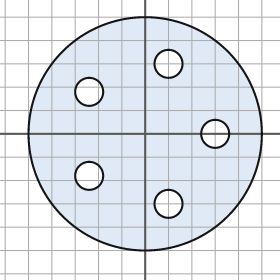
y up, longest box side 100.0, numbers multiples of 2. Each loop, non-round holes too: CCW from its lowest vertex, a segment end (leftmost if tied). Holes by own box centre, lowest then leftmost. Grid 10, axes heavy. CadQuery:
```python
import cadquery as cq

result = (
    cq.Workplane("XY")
    .moveTo(0.0, 0.0)
    .circle(50.0)
    .moveTo(10.0, -30.0)
    .circle(6.0)
    .moveTo(-24.0, -18.0)
    .circle(6.0)
    .moveTo(30.0, 0.0)
    .circle(6.0)
    .moveTo(-24.0, 18.0)
    .circle(6.0)
    .moveTo(10.0, 30.0)
    .circle(6.0)
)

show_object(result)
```